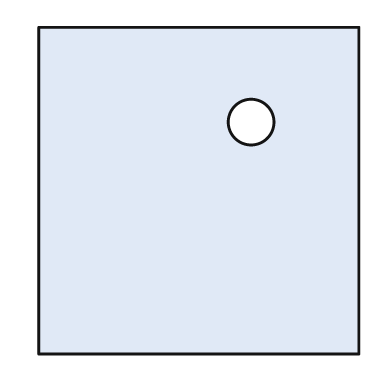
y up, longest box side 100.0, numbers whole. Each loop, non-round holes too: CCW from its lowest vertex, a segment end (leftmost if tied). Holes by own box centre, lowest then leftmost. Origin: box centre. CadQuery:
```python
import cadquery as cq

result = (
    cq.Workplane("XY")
    .moveTo(-49.0, -50.0)
    .lineTo(49.0, -50.0)
    .lineTo(49.0, 50.0)
    .lineTo(-49.0, 50.0)
    .close()
    .moveTo(16.0, 21.0)
    .circle(7.0)
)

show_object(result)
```